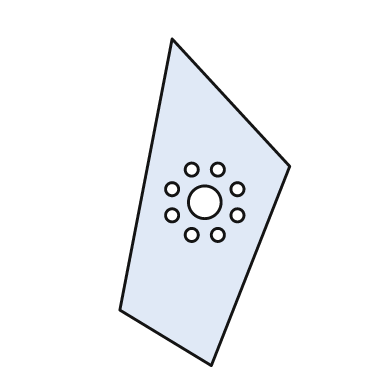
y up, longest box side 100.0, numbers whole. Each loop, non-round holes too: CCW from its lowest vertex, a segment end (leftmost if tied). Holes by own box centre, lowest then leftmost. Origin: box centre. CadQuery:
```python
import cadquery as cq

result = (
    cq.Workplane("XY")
    .moveTo(2.0, -50.0)
    .lineTo(26.0, 11.0)
    .lineTo(-10.0, 50.0)
    .lineTo(-26.0, -33.0)
    .close()
    .moveTo(-4.0, -10.0)
    .circle(2.0)
    .moveTo(4.0, -10.0)
    .circle(2.0)
    .moveTo(-10.0, -4.0)
    .circle(2.0)
    .moveTo(10.0, -4.0)
    .circle(2.0)
    .moveTo(0.0, 0.0)
    .circle(5.0)
    .moveTo(-10.0, 4.0)
    .circle(2.0)
    .moveTo(10.0, 4.0)
    .circle(2.0)
    .moveTo(-4.0, 10.0)
    .circle(2.0)
    .moveTo(4.0, 10.0)
    .circle(2.0)
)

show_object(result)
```